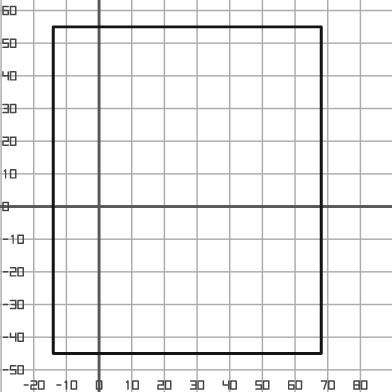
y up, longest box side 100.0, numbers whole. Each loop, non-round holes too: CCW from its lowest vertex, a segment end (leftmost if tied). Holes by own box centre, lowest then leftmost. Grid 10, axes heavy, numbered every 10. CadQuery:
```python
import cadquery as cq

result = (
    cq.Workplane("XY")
    .moveTo(-14.0, -45.0)
    .lineTo(68.0, -45.0)
    .lineTo(68.0, 55.0)
    .lineTo(-14.0, 55.0)
    .close()
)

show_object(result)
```